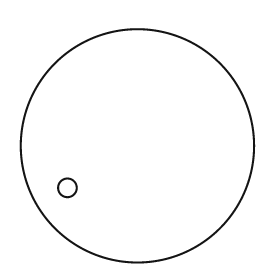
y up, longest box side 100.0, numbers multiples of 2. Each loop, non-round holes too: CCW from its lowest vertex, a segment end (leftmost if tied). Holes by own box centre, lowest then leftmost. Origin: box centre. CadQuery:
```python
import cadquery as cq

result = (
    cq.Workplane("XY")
    .moveTo(0.0, 0.0)
    .circle(50.0)
    .moveTo(-30.0, -18.0)
    .circle(4.0)
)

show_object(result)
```